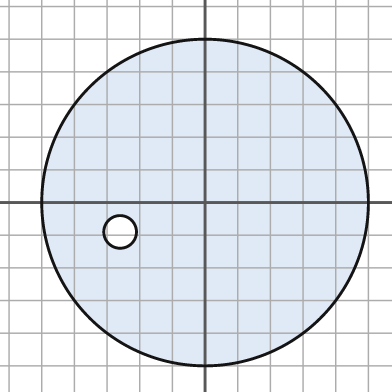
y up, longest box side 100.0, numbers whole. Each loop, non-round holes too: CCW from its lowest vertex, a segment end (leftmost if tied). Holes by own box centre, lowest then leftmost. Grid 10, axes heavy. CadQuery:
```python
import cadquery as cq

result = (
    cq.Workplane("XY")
    .moveTo(0.0, 0.0)
    .circle(50.0)
    .moveTo(-26.0, -9.0)
    .circle(5.0)
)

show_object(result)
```